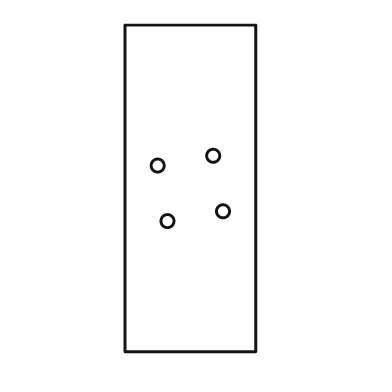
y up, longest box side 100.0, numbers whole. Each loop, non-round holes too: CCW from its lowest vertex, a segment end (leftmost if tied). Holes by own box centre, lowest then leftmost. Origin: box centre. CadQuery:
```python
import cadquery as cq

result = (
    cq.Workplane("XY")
    .moveTo(-20.0, -50.0)
    .lineTo(20.0, -50.0)
    .lineTo(20.0, 50.0)
    .lineTo(-20.0, 50.0)
    .close()
    .moveTo(-7.0, -10.0)
    .circle(2.0)
    .moveTo(10.0, -7.0)
    .circle(2.0)
    .moveTo(-10.0, 7.0)
    .circle(2.0)
    .moveTo(7.0, 10.0)
    .circle(2.0)
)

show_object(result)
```